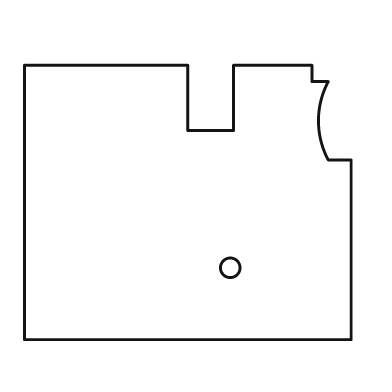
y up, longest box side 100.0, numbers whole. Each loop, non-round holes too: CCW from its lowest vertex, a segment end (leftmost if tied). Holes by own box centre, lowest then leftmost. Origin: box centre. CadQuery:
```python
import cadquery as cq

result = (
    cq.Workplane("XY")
    .moveTo(-50.0, -42.0)
    .lineTo(50.0, -42.0)
    .lineTo(50.0, 13.0)
    .lineTo(43.0, 13.0)
    .threePointArc((40.0, 25.0), (43.0, 37.0))
    .lineTo(38.0, 37.0)
    .lineTo(38.0, 42.0)
    .lineTo(14.0, 42.0)
    .lineTo(14.0, 22.0)
    .lineTo(0.0, 22.0)
    .lineTo(0.0, 42.0)
    .lineTo(-50.0, 42.0)
    .close()
    .moveTo(13.0, -20.0)
    .circle(3.0)
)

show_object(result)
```